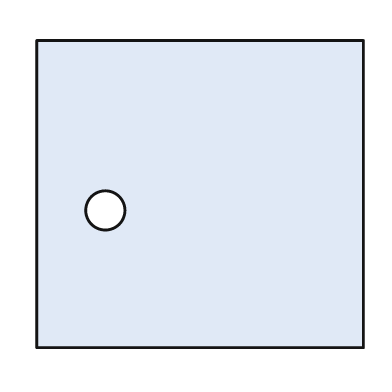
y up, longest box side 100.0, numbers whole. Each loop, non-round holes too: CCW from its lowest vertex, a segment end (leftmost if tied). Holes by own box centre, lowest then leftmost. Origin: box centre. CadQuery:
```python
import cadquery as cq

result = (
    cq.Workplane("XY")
    .moveTo(-50.0, -47.0)
    .lineTo(50.0, -47.0)
    .lineTo(50.0, 47.0)
    .lineTo(-50.0, 47.0)
    .close()
    .moveTo(-29.0, -5.0)
    .circle(6.0)
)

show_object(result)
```